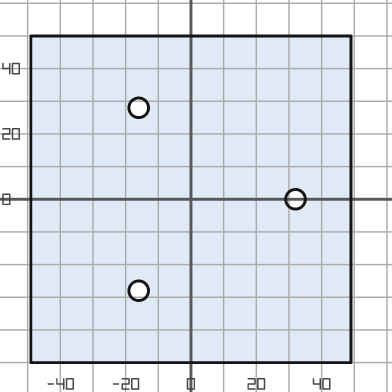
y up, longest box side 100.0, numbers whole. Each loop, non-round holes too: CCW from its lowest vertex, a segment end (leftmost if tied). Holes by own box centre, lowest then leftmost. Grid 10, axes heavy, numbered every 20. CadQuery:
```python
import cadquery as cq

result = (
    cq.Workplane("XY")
    .moveTo(-49.0, -50.0)
    .lineTo(49.0, -50.0)
    .lineTo(49.0, 50.0)
    .lineTo(-49.0, 50.0)
    .close()
    .moveTo(-16.0, -28.0)
    .circle(3.0)
    .moveTo(32.0, 0.0)
    .circle(3.0)
    .moveTo(-16.0, 28.0)
    .circle(3.0)
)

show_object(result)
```